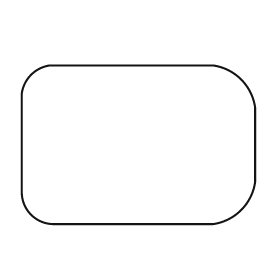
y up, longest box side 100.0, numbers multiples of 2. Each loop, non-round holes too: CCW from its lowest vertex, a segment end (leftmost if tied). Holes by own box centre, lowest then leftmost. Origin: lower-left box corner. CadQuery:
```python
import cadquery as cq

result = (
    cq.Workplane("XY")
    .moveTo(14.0, 0.0)
    .lineTo(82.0, 0.0)
    .threePointArc((94.0, 6.0), (100.0, 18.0))
    .lineTo(100.0, 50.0)
    .threePointArc((94.0, 62.0), (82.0, 68.0))
    .lineTo(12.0, 68.0)
    .threePointArc((4.0, 64.0), (0.0, 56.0))
    .lineTo(0.0, 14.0)
    .threePointArc((4.0, 4.0), (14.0, 0.0))
    .close()
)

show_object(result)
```